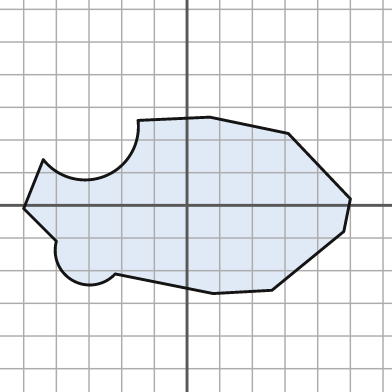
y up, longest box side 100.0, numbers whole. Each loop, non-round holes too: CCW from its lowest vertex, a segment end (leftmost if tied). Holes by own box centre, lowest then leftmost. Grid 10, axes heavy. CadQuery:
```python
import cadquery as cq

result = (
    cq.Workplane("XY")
    .moveTo(8.0, -27.0)
    .lineTo(26.0, -26.0)
    .lineTo(48.0, -8.0)
    .lineTo(50.0, 2.0)
    .lineTo(31.0, 22.0)
    .lineTo(7.0, 27.0)
    .lineTo(-15.0, 26.0)
    .threePointArc((-25.0, 9.0), (-44.0, 14.0))
    .lineTo(-50.0, -1.0)
    .lineTo(-40.0, -11.0)
    .threePointArc((-35.0, -23.0), (-22.0, -21.0))
    .close()
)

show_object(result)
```